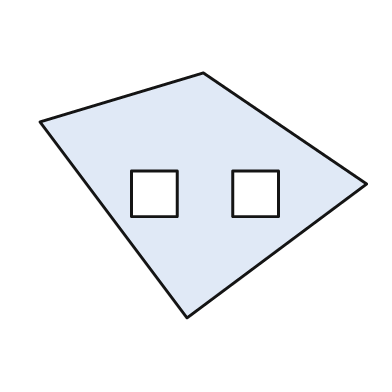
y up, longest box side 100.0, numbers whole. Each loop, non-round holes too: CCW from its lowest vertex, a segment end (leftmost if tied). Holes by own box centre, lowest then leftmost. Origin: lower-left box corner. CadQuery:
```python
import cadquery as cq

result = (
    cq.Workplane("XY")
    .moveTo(45.0, 0.0)
    .lineTo(100.0, 41.0)
    .lineTo(50.0, 75.0)
    .lineTo(0.0, 60.0)
    .close()
    .moveTo(28.0, 31.0)
    .lineTo(42.0, 31.0)
    .lineTo(42.0, 45.0)
    .lineTo(28.0, 45.0)
    .close()
    .moveTo(59.0, 31.0)
    .lineTo(73.0, 31.0)
    .lineTo(73.0, 45.0)
    .lineTo(59.0, 45.0)
    .close()
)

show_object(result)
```